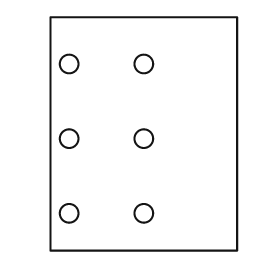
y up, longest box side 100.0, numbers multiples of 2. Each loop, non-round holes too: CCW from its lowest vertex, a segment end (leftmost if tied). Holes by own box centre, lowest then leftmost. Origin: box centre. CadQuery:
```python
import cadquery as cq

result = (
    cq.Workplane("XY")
    .moveTo(-40.0, -50.0)
    .lineTo(40.0, -50.0)
    .lineTo(40.0, 50.0)
    .lineTo(-40.0, 50.0)
    .close()
    .moveTo(-32.0, -34.0)
    .circle(4.0)
    .moveTo(0.0, -34.0)
    .circle(4.0)
    .moveTo(-32.0, -2.0)
    .circle(4.0)
    .moveTo(0.0, -2.0)
    .circle(4.0)
    .moveTo(-32.0, 30.0)
    .circle(4.0)
    .moveTo(0.0, 30.0)
    .circle(4.0)
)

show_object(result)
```